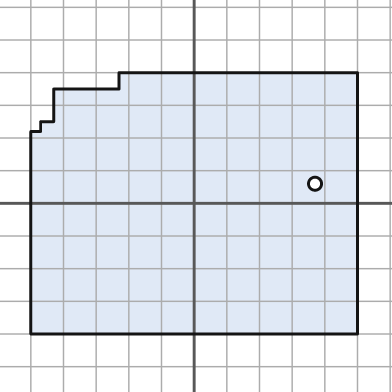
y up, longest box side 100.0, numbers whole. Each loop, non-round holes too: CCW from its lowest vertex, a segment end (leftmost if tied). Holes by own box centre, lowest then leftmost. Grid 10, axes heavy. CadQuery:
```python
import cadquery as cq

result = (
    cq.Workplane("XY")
    .moveTo(-50.0, -40.0)
    .lineTo(50.0, -40.0)
    .lineTo(50.0, 40.0)
    .lineTo(-23.0, 40.0)
    .lineTo(-23.0, 35.0)
    .lineTo(-43.0, 35.0)
    .lineTo(-43.0, 25.0)
    .lineTo(-47.0, 25.0)
    .lineTo(-47.0, 22.0)
    .lineTo(-50.0, 22.0)
    .close()
    .moveTo(37.0, 6.0)
    .circle(2.0)
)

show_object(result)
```